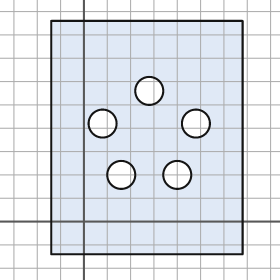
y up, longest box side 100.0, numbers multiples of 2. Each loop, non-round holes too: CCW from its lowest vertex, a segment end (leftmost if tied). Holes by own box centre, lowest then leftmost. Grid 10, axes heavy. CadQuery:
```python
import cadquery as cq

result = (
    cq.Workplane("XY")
    .moveTo(-14.0, -14.0)
    .lineTo(68.0, -14.0)
    .lineTo(68.0, 86.0)
    .lineTo(-14.0, 86.0)
    .close()
    .moveTo(16.0, 20.0)
    .circle(6.0)
    .moveTo(40.0, 20.0)
    .circle(6.0)
    .moveTo(8.0, 42.0)
    .circle(6.0)
    .moveTo(48.0, 42.0)
    .circle(6.0)
    .moveTo(28.0, 56.0)
    .circle(6.0)
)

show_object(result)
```